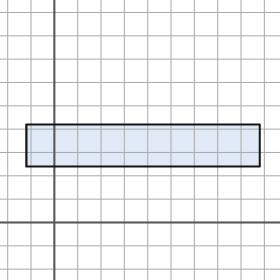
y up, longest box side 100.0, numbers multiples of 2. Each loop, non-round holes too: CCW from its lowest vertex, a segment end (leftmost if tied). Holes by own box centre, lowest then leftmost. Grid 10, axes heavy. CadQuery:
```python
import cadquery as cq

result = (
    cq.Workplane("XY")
    .moveTo(-12.0, 24.0)
    .lineTo(88.0, 24.0)
    .lineTo(88.0, 42.0)
    .lineTo(-12.0, 42.0)
    .close()
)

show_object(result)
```